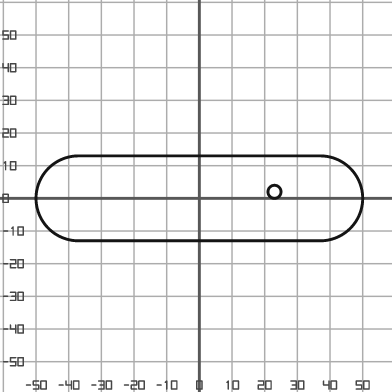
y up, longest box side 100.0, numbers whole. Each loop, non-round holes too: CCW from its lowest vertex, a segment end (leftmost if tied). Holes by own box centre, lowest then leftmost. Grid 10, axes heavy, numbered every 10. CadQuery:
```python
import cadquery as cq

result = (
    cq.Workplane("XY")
    .moveTo(-37.0, -13.0)
    .lineTo(37.0, -13.0)
    .threePointArc((50.0, 0.0), (37.0, 13.0))
    .lineTo(-37.0, 13.0)
    .threePointArc((-50.0, 0.0), (-37.0, -13.0))
    .close()
    .moveTo(23.0, 2.0)
    .circle(2.0)
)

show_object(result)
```